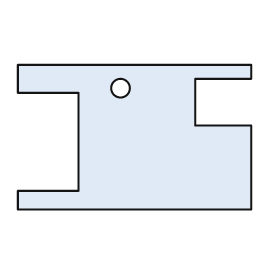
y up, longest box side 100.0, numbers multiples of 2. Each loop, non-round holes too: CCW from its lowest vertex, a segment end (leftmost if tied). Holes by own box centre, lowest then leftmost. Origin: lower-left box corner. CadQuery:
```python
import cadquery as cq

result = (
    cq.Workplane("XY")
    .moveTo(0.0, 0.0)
    .lineTo(100.0, 0.0)
    .lineTo(100.0, 36.0)
    .lineTo(76.0, 36.0)
    .lineTo(76.0, 56.0)
    .lineTo(100.0, 56.0)
    .lineTo(100.0, 62.0)
    .lineTo(0.0, 62.0)
    .lineTo(0.0, 50.0)
    .lineTo(26.0, 50.0)
    .lineTo(26.0, 8.0)
    .lineTo(0.0, 8.0)
    .close()
    .moveTo(44.0, 52.0)
    .circle(4.0)
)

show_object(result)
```